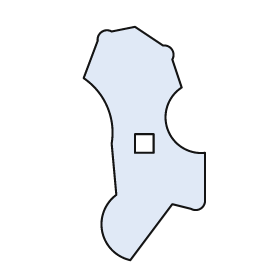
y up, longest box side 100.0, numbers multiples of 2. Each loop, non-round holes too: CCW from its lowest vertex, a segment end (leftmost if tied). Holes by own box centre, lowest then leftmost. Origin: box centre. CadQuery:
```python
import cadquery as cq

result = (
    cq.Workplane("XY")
    .moveTo(-6.0, -50.0)
    .lineTo(12.0, -26.0)
    .lineTo(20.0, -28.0)
    .threePointArc((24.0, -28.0), (26.0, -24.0))
    .lineTo(26.0, -4.0)
    .threePointArc((10.0, 6.0), (16.0, 24.0))
    .lineTo(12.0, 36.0)
    .threePointArc((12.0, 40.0), (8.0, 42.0))
    .lineTo(-4.0, 50.0)
    .lineTo(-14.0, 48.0)
    .threePointArc((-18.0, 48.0), (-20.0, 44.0))
    .lineTo(-26.0, 28.0)
    .threePointArc((-16.0, 16.0), (-14.0, 0.0))
    .lineTo(-12.0, -22.0)
    .threePointArc((-18.0, -38.0), (-6.0, -50.0))
    .close()
    .moveTo(-4.0, -4.0)
    .lineTo(4.0, -4.0)
    .lineTo(4.0, 4.0)
    .lineTo(-4.0, 4.0)
    .close()
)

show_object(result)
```